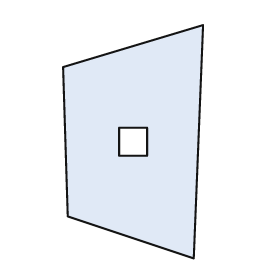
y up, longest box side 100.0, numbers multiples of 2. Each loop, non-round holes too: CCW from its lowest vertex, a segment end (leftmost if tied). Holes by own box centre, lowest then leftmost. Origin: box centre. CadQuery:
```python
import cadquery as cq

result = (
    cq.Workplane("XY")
    .moveTo(26.0, -50.0)
    .lineTo(30.0, 50.0)
    .lineTo(-30.0, 32.0)
    .lineTo(-28.0, -32.0)
    .close()
    .moveTo(-6.0, -6.0)
    .lineTo(6.0, -6.0)
    .lineTo(6.0, 6.0)
    .lineTo(-6.0, 6.0)
    .close()
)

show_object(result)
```